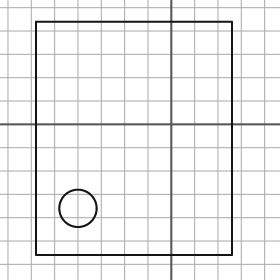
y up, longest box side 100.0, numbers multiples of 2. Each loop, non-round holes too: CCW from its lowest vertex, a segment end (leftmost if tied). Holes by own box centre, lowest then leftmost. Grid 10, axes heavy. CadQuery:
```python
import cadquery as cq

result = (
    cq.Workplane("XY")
    .moveTo(-58.0, -56.0)
    .lineTo(26.0, -56.0)
    .lineTo(26.0, 44.0)
    .lineTo(-58.0, 44.0)
    .close()
    .moveTo(-40.0, -36.0)
    .circle(8.0)
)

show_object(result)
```